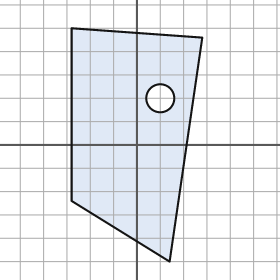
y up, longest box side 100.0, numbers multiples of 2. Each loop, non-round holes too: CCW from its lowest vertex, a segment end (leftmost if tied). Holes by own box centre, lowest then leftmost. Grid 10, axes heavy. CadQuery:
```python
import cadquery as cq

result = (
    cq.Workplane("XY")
    .moveTo(14.0, -50.0)
    .lineTo(28.0, 46.0)
    .lineTo(-28.0, 50.0)
    .lineTo(-28.0, -24.0)
    .close()
    .moveTo(10.0, 20.0)
    .circle(6.0)
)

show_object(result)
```